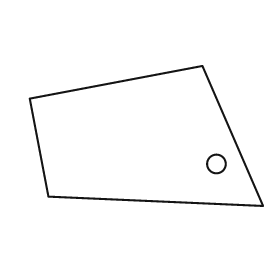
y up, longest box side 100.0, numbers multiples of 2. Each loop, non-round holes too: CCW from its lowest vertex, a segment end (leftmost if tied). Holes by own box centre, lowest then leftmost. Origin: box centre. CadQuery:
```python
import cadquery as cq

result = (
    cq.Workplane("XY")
    .moveTo(50.0, -30.0)
    .lineTo(24.0, 30.0)
    .lineTo(-50.0, 16.0)
    .lineTo(-42.0, -26.0)
    .close()
    .moveTo(30.0, -12.0)
    .circle(4.0)
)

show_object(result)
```